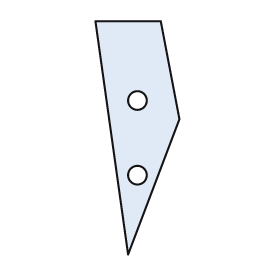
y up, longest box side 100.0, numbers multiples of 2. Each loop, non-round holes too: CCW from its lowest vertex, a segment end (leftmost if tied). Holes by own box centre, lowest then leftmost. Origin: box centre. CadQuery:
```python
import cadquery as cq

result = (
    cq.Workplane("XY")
    .moveTo(-4.0, -50.0)
    .lineTo(18.0, 8.0)
    .lineTo(10.0, 50.0)
    .lineTo(-18.0, 50.0)
    .close()
    .moveTo(0.0, -16.0)
    .circle(4.0)
    .moveTo(0.0, 16.0)
    .circle(4.0)
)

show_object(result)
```